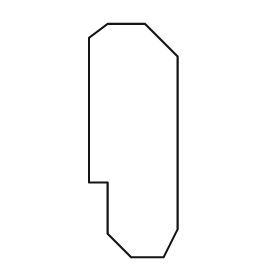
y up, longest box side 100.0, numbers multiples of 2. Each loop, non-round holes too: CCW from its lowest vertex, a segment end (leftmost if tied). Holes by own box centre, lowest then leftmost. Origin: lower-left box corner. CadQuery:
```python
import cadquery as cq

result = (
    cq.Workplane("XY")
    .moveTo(18.0, 0.0)
    .lineTo(32.0, 0.0)
    .lineTo(38.0, 12.0)
    .lineTo(38.0, 86.0)
    .lineTo(24.0, 100.0)
    .lineTo(8.0, 100.0)
    .lineTo(0.0, 94.0)
    .lineTo(0.0, 32.0)
    .lineTo(8.0, 32.0)
    .lineTo(8.0, 10.0)
    .close()
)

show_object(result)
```